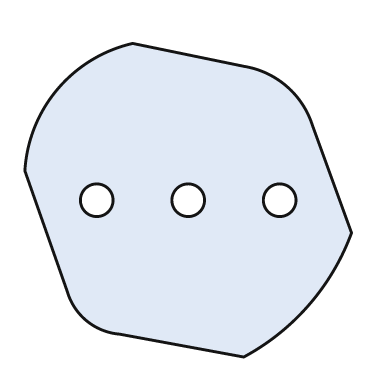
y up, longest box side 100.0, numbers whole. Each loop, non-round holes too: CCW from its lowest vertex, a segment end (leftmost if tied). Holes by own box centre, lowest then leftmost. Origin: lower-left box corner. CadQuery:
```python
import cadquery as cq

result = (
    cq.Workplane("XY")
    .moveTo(67.0, 0.0)
    .threePointArc((87.0, 16.0), (100.0, 38.0))
    .lineTo(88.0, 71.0)
    .threePointArc((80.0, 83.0), (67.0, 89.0))
    .lineTo(33.0, 96.0)
    .threePointArc((10.0, 82.0), (0.0, 57.0))
    .lineTo(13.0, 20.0)
    .threePointArc((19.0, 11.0), (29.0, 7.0))
    .close()
    .moveTo(22.0, 48.0)
    .circle(5.0)
    .moveTo(50.0, 48.0)
    .circle(5.0)
    .moveTo(78.0, 48.0)
    .circle(5.0)
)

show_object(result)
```